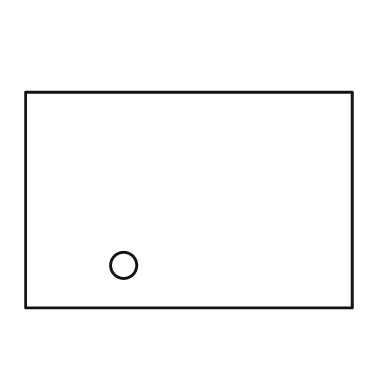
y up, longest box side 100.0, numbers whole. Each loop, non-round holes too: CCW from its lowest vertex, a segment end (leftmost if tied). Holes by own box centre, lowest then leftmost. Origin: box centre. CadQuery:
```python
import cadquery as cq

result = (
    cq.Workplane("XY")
    .moveTo(-50.0, -33.0)
    .lineTo(50.0, -33.0)
    .lineTo(50.0, 33.0)
    .lineTo(-50.0, 33.0)
    .close()
    .moveTo(-20.0, -20.0)
    .circle(4.0)
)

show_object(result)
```